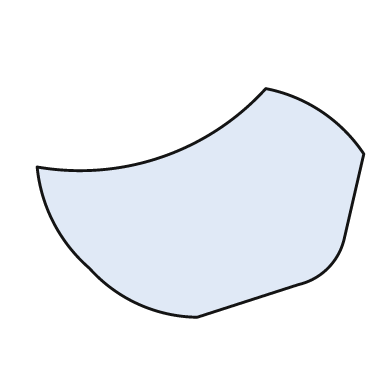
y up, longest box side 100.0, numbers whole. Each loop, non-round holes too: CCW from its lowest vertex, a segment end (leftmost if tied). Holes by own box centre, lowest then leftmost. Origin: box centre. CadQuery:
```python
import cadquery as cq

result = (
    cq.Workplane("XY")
    .moveTo(-1.0, -35.0)
    .lineTo(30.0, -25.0)
    .threePointArc((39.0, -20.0), (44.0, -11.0))
    .lineTo(50.0, 15.0)
    .threePointArc((37.0, 28.0), (20.0, 35.0))
    .threePointArc((-12.0, 14.0), (-50.0, 11.0))
    .threePointArc((-45.0, -6.0), (-34.0, -20.0))
    .threePointArc((-19.0, -31.0), (-1.0, -35.0))
    .close()
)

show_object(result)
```